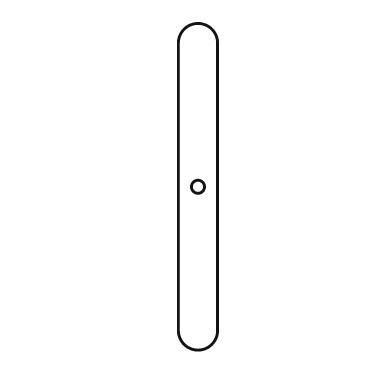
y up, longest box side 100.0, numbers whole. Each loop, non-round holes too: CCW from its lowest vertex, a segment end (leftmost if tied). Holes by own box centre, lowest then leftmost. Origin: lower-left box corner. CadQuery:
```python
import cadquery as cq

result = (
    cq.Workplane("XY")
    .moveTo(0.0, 6.0)
    .threePointArc((6.0, 0.0), (12.0, 6.0))
    .lineTo(12.0, 94.0)
    .threePointArc((6.0, 100.0), (0.0, 94.0))
    .close()
    .moveTo(6.0, 50.0)
    .circle(2.0)
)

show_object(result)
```